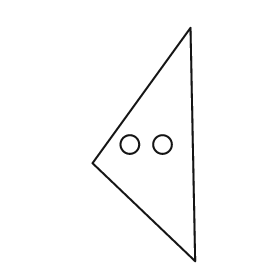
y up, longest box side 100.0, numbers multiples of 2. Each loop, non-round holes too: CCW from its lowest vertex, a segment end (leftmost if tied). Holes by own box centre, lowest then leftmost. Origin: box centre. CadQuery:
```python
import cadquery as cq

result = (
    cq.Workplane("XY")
    .moveTo(22.0, -50.0)
    .lineTo(20.0, 50.0)
    .lineTo(-22.0, -8.0)
    .close()
    .moveTo(-6.0, 0.0)
    .circle(4.0)
    .moveTo(8.0, 0.0)
    .circle(4.0)
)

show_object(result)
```